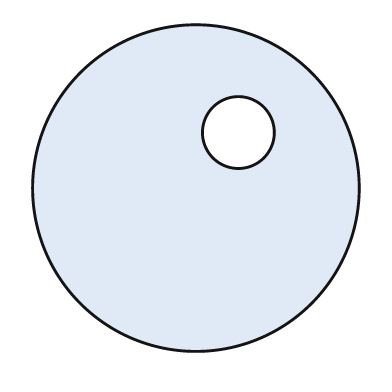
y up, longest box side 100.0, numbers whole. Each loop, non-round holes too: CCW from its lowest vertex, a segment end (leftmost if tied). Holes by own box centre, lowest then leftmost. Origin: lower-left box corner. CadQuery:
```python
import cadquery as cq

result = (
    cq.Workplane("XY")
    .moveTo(50.0, 50.0)
    .circle(50.0)
    .moveTo(63.0, 67.0)
    .circle(11.0)
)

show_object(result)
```